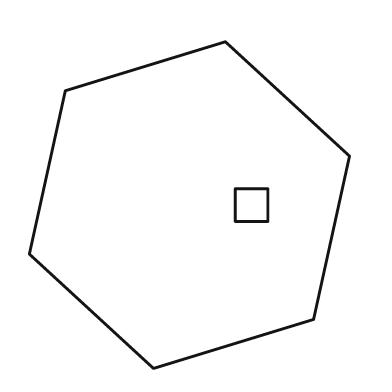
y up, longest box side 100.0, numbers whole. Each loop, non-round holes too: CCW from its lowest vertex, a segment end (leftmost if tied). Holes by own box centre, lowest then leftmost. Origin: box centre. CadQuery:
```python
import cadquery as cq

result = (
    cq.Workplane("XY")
    .moveTo(-11.0, -50.0)
    .lineTo(38.0, -35.0)
    .lineTo(49.0, 15.0)
    .lineTo(11.0, 50.0)
    .lineTo(-38.0, 35.0)
    .lineTo(-49.0, -15.0)
    .close()
    .moveTo(14.0, -5.0)
    .lineTo(24.0, -5.0)
    .lineTo(24.0, 5.0)
    .lineTo(14.0, 5.0)
    .close()
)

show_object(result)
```